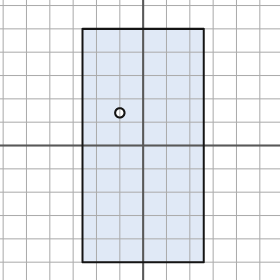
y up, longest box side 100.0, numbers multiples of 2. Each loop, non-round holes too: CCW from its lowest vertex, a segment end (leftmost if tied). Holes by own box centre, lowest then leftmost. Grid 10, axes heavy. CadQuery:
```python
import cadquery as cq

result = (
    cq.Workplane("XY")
    .moveTo(-26.0, -50.0)
    .lineTo(26.0, -50.0)
    .lineTo(26.0, 50.0)
    .lineTo(-26.0, 50.0)
    .close()
    .moveTo(-10.0, 14.0)
    .circle(2.0)
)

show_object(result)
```